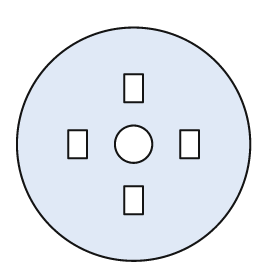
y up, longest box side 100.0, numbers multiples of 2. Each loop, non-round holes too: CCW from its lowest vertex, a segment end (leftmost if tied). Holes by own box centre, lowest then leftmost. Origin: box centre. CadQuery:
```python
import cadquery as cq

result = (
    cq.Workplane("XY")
    .moveTo(0.0, 0.0)
    .circle(50.0)
    .moveTo(-4.0, -30.0)
    .lineTo(4.0, -30.0)
    .lineTo(4.0, -18.0)
    .lineTo(-4.0, -18.0)
    .close()
    .moveTo(-28.0, -6.0)
    .lineTo(-20.0, -6.0)
    .lineTo(-20.0, 6.0)
    .lineTo(-28.0, 6.0)
    .close()
    .moveTo(0.0, 0.0)
    .circle(8.0)
    .moveTo(20.0, -6.0)
    .lineTo(28.0, -6.0)
    .lineTo(28.0, 6.0)
    .lineTo(20.0, 6.0)
    .close()
    .moveTo(-4.0, 18.0)
    .lineTo(4.0, 18.0)
    .lineTo(4.0, 30.0)
    .lineTo(-4.0, 30.0)
    .close()
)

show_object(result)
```